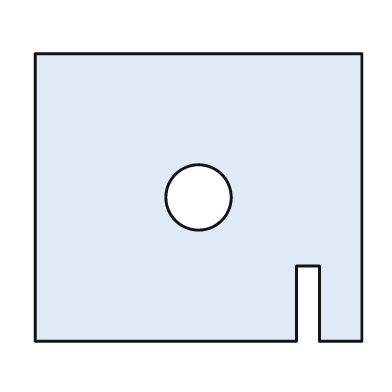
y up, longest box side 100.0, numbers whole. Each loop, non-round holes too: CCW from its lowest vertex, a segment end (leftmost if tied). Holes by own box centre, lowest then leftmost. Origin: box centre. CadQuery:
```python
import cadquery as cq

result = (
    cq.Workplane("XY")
    .moveTo(-50.0, -44.0)
    .lineTo(30.0, -44.0)
    .lineTo(30.0, -21.0)
    .lineTo(37.0, -21.0)
    .lineTo(37.0, -44.0)
    .lineTo(50.0, -44.0)
    .lineTo(50.0, 44.0)
    .lineTo(-50.0, 44.0)
    .close()
    .moveTo(0.0, 0.0)
    .circle(10.0)
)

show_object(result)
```